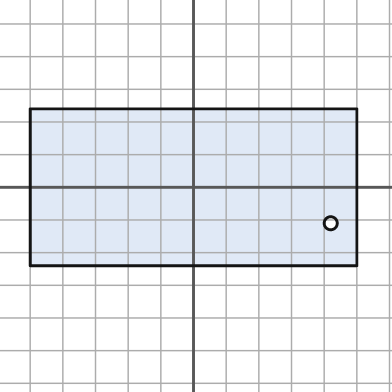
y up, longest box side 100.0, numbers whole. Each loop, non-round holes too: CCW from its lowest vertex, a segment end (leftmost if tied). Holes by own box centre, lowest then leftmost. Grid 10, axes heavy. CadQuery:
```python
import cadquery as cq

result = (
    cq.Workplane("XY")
    .moveTo(-50.0, -24.0)
    .lineTo(50.0, -24.0)
    .lineTo(50.0, 24.0)
    .lineTo(-50.0, 24.0)
    .close()
    .moveTo(42.0, -11.0)
    .circle(2.0)
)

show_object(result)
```